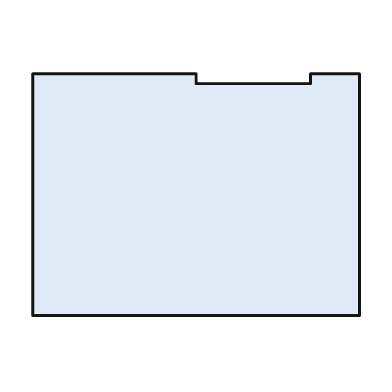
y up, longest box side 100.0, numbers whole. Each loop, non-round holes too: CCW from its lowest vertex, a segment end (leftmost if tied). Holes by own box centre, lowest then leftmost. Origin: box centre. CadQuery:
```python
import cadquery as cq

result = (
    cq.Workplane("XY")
    .moveTo(-50.0, -37.0)
    .lineTo(50.0, -37.0)
    .lineTo(50.0, 37.0)
    .lineTo(35.0, 37.0)
    .lineTo(35.0, 34.0)
    .lineTo(0.0, 34.0)
    .lineTo(0.0, 37.0)
    .lineTo(-50.0, 37.0)
    .close()
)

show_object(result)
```